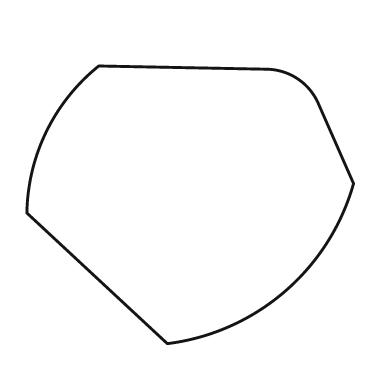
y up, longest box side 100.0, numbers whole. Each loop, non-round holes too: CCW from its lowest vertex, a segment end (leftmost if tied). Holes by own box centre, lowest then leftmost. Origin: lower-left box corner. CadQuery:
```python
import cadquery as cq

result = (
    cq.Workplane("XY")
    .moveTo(43.0, 0.0)
    .threePointArc((79.0, 16.0), (100.0, 49.0))
    .lineTo(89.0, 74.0)
    .threePointArc((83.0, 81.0), (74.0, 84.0))
    .lineTo(22.0, 85.0)
    .threePointArc((6.0, 65.0), (0.0, 40.0))
    .close()
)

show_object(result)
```